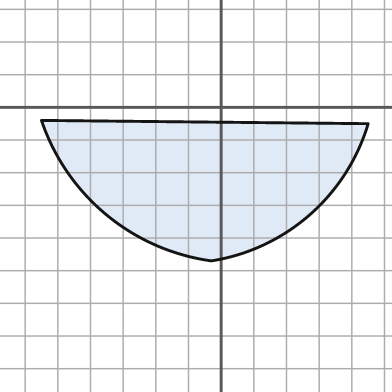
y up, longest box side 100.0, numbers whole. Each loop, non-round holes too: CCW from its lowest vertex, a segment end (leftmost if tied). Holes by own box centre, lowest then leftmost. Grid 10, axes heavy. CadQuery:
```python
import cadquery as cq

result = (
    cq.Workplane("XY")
    .moveTo(-3.0, -47.0)
    .threePointArc((27.0, -33.0), (45.0, -5.0))
    .lineTo(-55.0, -4.0)
    .threePointArc((-35.0, -33.0), (-3.0, -47.0))
    .close()
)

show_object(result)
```